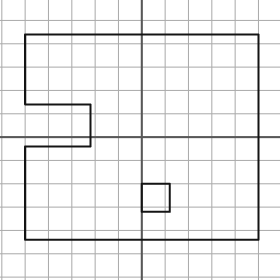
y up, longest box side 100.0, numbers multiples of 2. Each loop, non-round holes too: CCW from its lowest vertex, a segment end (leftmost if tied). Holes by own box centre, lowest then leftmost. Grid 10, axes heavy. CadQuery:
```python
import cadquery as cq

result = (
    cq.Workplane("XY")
    .moveTo(-50.0, -44.0)
    .lineTo(50.0, -44.0)
    .lineTo(50.0, 44.0)
    .lineTo(-50.0, 44.0)
    .lineTo(-50.0, 14.0)
    .lineTo(-22.0, 14.0)
    .lineTo(-22.0, -4.0)
    .lineTo(-50.0, -4.0)
    .close()
    .moveTo(0.0, -32.0)
    .lineTo(12.0, -32.0)
    .lineTo(12.0, -20.0)
    .lineTo(0.0, -20.0)
    .close()
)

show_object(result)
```